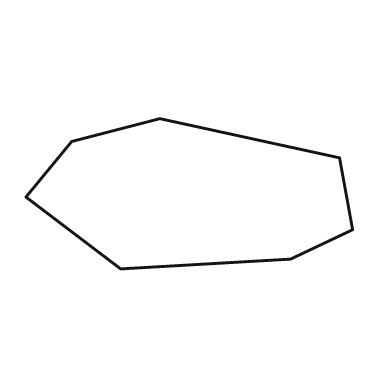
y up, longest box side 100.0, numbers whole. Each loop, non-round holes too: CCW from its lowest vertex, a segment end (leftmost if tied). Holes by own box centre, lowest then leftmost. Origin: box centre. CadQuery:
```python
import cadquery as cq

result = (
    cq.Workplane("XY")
    .moveTo(-21.0, -23.0)
    .lineTo(31.0, -20.0)
    .lineTo(50.0, -11.0)
    .lineTo(46.0, 11.0)
    .lineTo(-9.0, 23.0)
    .lineTo(-36.0, 16.0)
    .lineTo(-50.0, -1.0)
    .close()
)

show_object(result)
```